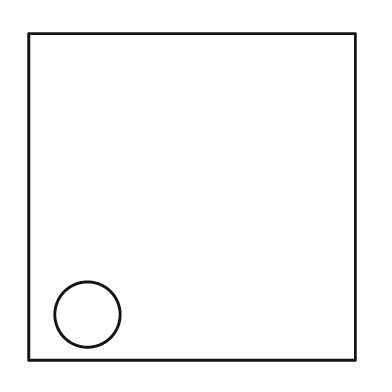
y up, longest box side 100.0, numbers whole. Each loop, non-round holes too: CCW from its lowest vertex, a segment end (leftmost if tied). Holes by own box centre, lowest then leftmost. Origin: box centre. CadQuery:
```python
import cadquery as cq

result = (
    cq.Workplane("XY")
    .moveTo(-50.0, -50.0)
    .lineTo(50.0, -50.0)
    .lineTo(50.0, 50.0)
    .lineTo(-50.0, 50.0)
    .close()
    .moveTo(-32.0, -36.0)
    .circle(10.0)
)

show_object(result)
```